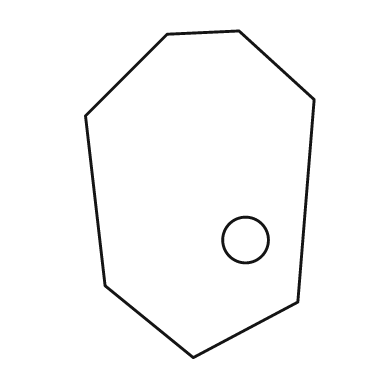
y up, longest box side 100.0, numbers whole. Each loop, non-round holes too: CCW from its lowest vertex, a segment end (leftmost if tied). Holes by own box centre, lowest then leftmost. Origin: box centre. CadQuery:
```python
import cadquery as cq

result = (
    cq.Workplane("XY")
    .moveTo(-2.0, -50.0)
    .lineTo(30.0, -33.0)
    .lineTo(35.0, 29.0)
    .lineTo(12.0, 50.0)
    .lineTo(-10.0, 49.0)
    .lineTo(-35.0, 24.0)
    .lineTo(-29.0, -28.0)
    .close()
    .moveTo(14.0, -14.0)
    .circle(7.0)
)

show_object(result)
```